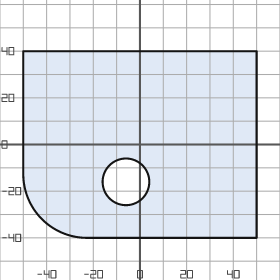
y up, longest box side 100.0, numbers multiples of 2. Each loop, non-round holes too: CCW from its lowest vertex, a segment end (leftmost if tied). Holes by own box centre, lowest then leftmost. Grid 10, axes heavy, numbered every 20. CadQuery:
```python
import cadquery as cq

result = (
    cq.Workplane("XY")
    .moveTo(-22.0, -40.0)
    .lineTo(50.0, -40.0)
    .lineTo(50.0, 40.0)
    .lineTo(-50.0, 40.0)
    .lineTo(-50.0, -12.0)
    .threePointArc((-42.0, -32.0), (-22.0, -40.0))
    .close()
    .moveTo(-6.0, -16.0)
    .circle(10.0)
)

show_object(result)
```